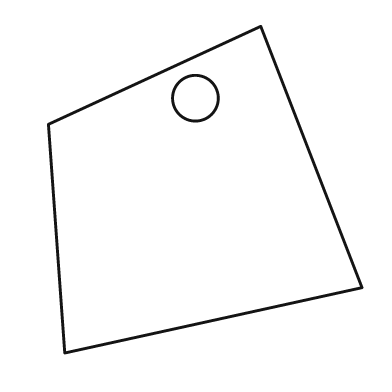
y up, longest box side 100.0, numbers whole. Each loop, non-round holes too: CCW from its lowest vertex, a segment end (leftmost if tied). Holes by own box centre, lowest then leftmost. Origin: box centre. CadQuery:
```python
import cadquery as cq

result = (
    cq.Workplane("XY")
    .moveTo(-43.0, -50.0)
    .lineTo(48.0, -30.0)
    .lineTo(17.0, 50.0)
    .lineTo(-48.0, 20.0)
    .close()
    .moveTo(-3.0, 28.0)
    .circle(7.0)
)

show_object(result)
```